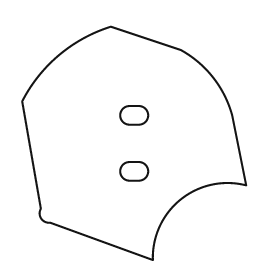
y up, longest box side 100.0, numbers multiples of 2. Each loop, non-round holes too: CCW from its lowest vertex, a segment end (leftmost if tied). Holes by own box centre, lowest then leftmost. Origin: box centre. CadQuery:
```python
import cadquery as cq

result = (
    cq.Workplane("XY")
    .moveTo(8.0, -50.0)
    .threePointArc((20.0, -24.0), (48.0, -18.0))
    .lineTo(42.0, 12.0)
    .threePointArc((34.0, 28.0), (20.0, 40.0))
    .lineTo(-10.0, 50.0)
    .threePointArc((-32.0, 38.0), (-48.0, 18.0))
    .lineTo(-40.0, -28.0)
    .threePointArc((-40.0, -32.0), (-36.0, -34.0))
    .close()
    .moveTo(-2.0, -16.0)
    .lineTo(2.0, -16.0)
    .threePointArc((6.0, -12.0), (2.0, -8.0))
    .lineTo(-2.0, -8.0)
    .threePointArc((-6.0, -12.0), (-2.0, -16.0))
    .close()
    .moveTo(-2.0, 8.0)
    .lineTo(2.0, 8.0)
    .threePointArc((6.0, 12.0), (2.0, 16.0))
    .lineTo(-2.0, 16.0)
    .threePointArc((-6.0, 12.0), (-2.0, 8.0))
    .close()
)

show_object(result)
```